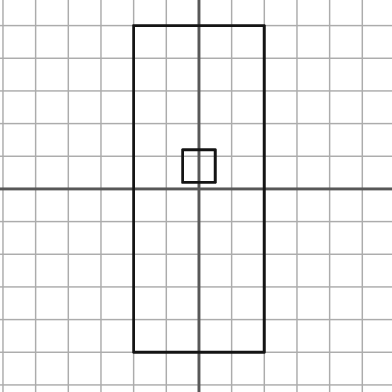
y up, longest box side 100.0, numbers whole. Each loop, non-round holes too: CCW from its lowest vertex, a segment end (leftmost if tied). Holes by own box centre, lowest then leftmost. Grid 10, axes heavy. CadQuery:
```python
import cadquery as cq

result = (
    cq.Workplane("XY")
    .moveTo(-20.0, -50.0)
    .lineTo(20.0, -50.0)
    .lineTo(20.0, 50.0)
    .lineTo(-20.0, 50.0)
    .close()
    .moveTo(-5.0, 2.0)
    .lineTo(5.0, 2.0)
    .lineTo(5.0, 12.0)
    .lineTo(-5.0, 12.0)
    .close()
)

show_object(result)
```